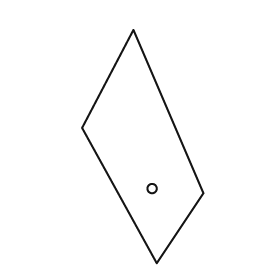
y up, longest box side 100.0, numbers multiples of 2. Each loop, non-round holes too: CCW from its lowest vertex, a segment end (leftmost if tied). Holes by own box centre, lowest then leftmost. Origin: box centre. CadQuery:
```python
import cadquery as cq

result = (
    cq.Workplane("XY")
    .moveTo(6.0, -50.0)
    .lineTo(26.0, -20.0)
    .lineTo(-4.0, 50.0)
    .lineTo(-26.0, 8.0)
    .close()
    .moveTo(4.0, -18.0)
    .circle(2.0)
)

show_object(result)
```